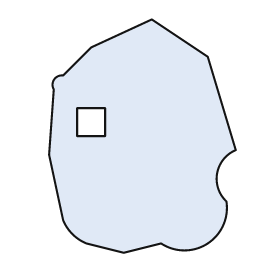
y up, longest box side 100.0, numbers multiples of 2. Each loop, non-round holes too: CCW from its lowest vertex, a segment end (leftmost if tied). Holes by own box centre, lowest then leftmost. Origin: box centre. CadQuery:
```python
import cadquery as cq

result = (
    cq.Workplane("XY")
    .moveTo(-8.0, -50.0)
    .lineTo(8.0, -46.0)
    .threePointArc((28.0, -46.0), (36.0, -28.0))
    .threePointArc((32.0, -16.0), (40.0, -6.0))
    .lineTo(28.0, 34.0)
    .lineTo(4.0, 50.0)
    .lineTo(-22.0, 38.0)
    .lineTo(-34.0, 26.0)
    .threePointArc((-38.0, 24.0), (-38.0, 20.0))
    .lineTo(-40.0, -8.0)
    .lineTo(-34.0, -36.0)
    .threePointArc((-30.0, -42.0), (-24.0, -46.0))
    .close()
    .moveTo(-28.0, 0.0)
    .lineTo(-16.0, 0.0)
    .lineTo(-16.0, 12.0)
    .lineTo(-28.0, 12.0)
    .close()
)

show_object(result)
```